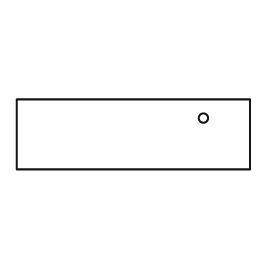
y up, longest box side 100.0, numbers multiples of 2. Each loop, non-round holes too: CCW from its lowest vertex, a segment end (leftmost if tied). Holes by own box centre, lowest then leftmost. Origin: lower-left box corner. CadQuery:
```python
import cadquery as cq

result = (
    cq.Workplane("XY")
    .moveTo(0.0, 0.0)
    .lineTo(100.0, 0.0)
    .lineTo(100.0, 30.0)
    .lineTo(0.0, 30.0)
    .close()
    .moveTo(80.0, 22.0)
    .circle(2.0)
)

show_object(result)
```